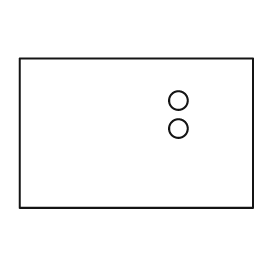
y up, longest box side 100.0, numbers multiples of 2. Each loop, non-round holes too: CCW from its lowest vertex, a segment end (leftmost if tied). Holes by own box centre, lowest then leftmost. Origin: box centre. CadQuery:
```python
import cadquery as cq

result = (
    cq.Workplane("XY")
    .moveTo(-50.0, -32.0)
    .lineTo(50.0, -32.0)
    .lineTo(50.0, 32.0)
    .lineTo(-50.0, 32.0)
    .close()
    .moveTo(18.0, 2.0)
    .circle(4.0)
    .moveTo(18.0, 14.0)
    .circle(4.0)
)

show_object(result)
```